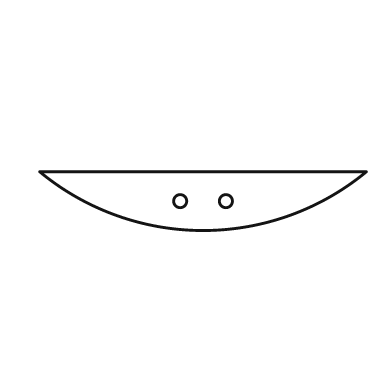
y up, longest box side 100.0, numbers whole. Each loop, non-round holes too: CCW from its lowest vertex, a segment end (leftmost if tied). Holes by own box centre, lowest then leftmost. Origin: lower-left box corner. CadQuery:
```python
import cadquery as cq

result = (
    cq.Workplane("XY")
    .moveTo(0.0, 18.0)
    .threePointArc((50.0, 0.0), (100.0, 18.0))
    .close()
    .moveTo(43.0, 9.0)
    .circle(2.0)
    .moveTo(57.0, 9.0)
    .circle(2.0)
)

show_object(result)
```